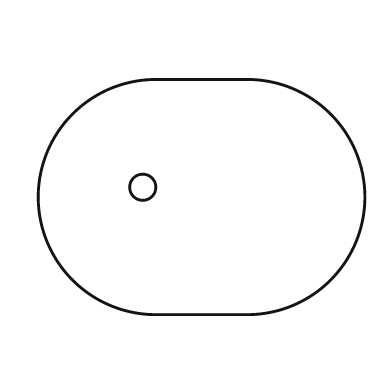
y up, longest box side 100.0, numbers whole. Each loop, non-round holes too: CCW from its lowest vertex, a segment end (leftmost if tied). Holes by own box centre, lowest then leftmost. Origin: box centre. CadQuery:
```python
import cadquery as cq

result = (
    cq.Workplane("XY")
    .moveTo(-14.0, -36.0)
    .lineTo(14.0, -36.0)
    .threePointArc((50.0, 0.0), (14.0, 36.0))
    .lineTo(-14.0, 36.0)
    .threePointArc((-50.0, 0.0), (-14.0, -36.0))
    .close()
    .moveTo(-18.0, 3.0)
    .circle(4.0)
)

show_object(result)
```